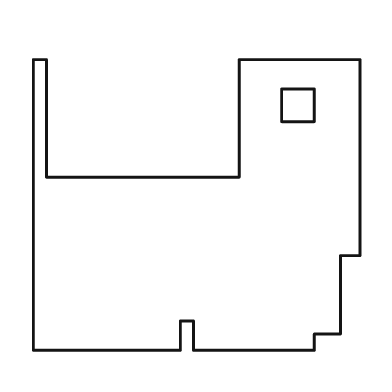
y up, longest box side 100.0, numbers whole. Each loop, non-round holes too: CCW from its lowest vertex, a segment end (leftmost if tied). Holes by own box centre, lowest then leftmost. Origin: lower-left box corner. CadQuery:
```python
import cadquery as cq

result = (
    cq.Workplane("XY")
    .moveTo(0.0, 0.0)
    .lineTo(45.0, 0.0)
    .lineTo(45.0, 9.0)
    .lineTo(49.0, 9.0)
    .lineTo(49.0, 0.0)
    .lineTo(86.0, 0.0)
    .lineTo(86.0, 5.0)
    .lineTo(94.0, 5.0)
    .lineTo(94.0, 29.0)
    .lineTo(100.0, 29.0)
    .lineTo(100.0, 89.0)
    .lineTo(63.0, 89.0)
    .lineTo(63.0, 53.0)
    .lineTo(4.0, 53.0)
    .lineTo(4.0, 89.0)
    .lineTo(0.0, 89.0)
    .close()
    .moveTo(76.0, 70.0)
    .lineTo(86.0, 70.0)
    .lineTo(86.0, 80.0)
    .lineTo(76.0, 80.0)
    .close()
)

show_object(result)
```